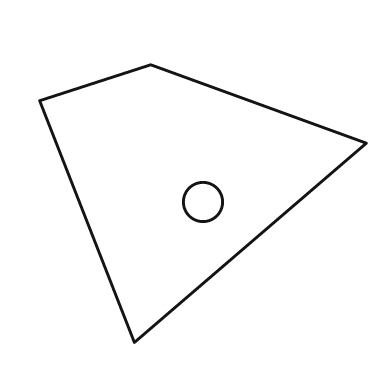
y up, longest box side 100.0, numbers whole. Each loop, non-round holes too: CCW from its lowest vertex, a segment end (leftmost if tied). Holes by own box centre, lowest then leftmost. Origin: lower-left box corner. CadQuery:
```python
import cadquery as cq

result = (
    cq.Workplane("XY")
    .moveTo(29.0, 0.0)
    .lineTo(100.0, 61.0)
    .lineTo(34.0, 85.0)
    .lineTo(0.0, 74.0)
    .close()
    .moveTo(50.0, 43.0)
    .circle(6.0)
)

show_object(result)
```